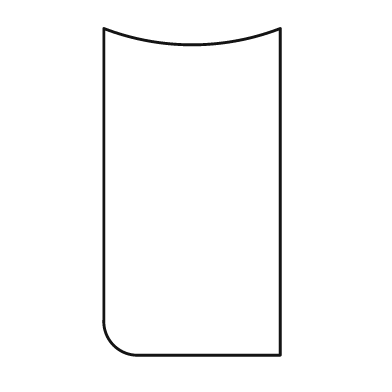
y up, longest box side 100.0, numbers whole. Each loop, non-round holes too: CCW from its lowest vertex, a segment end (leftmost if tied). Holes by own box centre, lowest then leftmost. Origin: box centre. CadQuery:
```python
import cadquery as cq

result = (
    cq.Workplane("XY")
    .moveTo(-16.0, -50.0)
    .lineTo(27.0, -50.0)
    .lineTo(27.0, 50.0)
    .threePointArc((0.0, 45.0), (-27.0, 50.0))
    .lineTo(-27.0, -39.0)
    .threePointArc((-24.0, -47.0), (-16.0, -50.0))
    .close()
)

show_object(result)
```